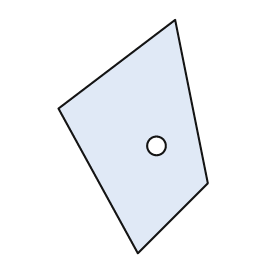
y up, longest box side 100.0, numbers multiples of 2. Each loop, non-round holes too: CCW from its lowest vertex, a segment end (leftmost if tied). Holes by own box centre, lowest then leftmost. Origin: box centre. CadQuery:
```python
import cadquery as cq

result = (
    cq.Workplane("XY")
    .moveTo(2.0, -50.0)
    .lineTo(32.0, -20.0)
    .lineTo(18.0, 50.0)
    .lineTo(-32.0, 12.0)
    .close()
    .moveTo(10.0, -4.0)
    .circle(4.0)
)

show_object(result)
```